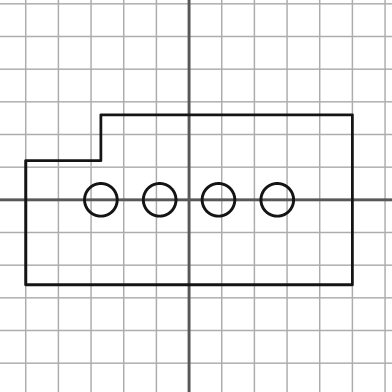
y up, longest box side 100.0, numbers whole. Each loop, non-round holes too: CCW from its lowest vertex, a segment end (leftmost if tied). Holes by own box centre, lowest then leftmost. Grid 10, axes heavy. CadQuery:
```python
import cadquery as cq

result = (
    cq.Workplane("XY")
    .moveTo(-50.0, -26.0)
    .lineTo(50.0, -26.0)
    .lineTo(50.0, 26.0)
    .lineTo(-27.0, 26.0)
    .lineTo(-27.0, 12.0)
    .lineTo(-50.0, 12.0)
    .close()
    .moveTo(-27.0, 0.0)
    .circle(5.0)
    .moveTo(-9.0, 0.0)
    .circle(5.0)
    .moveTo(9.0, 0.0)
    .circle(5.0)
    .moveTo(27.0, 0.0)
    .circle(5.0)
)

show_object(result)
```